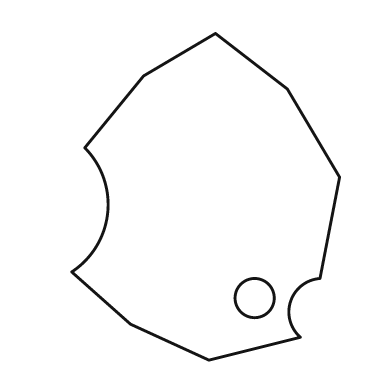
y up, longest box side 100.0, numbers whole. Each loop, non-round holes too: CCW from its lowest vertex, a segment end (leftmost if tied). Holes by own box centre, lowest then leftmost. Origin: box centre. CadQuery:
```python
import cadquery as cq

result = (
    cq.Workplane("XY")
    .moveTo(1.0, -50.0)
    .lineTo(29.0, -43.0)
    .threePointArc((26.0, -32.0), (35.0, -25.0))
    .lineTo(41.0, 6.0)
    .lineTo(25.0, 33.0)
    .lineTo(3.0, 50.0)
    .lineTo(-19.0, 37.0)
    .lineTo(-37.0, 15.0)
    .threePointArc((-30.0, -5.0), (-41.0, -23.0))
    .lineTo(-23.0, -39.0)
    .close()
    .moveTo(15.0, -31.0)
    .circle(6.0)
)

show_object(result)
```